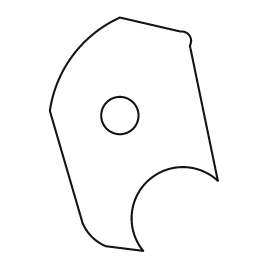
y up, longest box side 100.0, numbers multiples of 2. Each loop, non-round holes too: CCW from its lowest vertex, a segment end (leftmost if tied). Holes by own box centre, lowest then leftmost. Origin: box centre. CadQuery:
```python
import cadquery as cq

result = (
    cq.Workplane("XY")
    .moveTo(4.0, -50.0)
    .threePointArc((6.0, -20.0), (36.0, -20.0))
    .lineTo(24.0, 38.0)
    .threePointArc((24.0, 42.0), (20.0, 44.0))
    .lineTo(-6.0, 50.0)
    .threePointArc((-26.0, 34.0), (-36.0, 10.0))
    .lineTo(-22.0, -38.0)
    .threePointArc((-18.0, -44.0), (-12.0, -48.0))
    .close()
    .moveTo(-6.0, 8.0)
    .circle(8.0)
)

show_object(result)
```